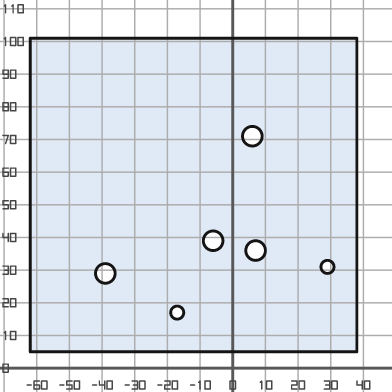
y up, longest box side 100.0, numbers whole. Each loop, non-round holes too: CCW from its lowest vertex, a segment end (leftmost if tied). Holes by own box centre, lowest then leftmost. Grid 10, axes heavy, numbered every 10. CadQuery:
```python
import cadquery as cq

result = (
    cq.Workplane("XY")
    .moveTo(-62.0, 5.0)
    .lineTo(38.0, 5.0)
    .lineTo(38.0, 101.0)
    .lineTo(-62.0, 101.0)
    .close()
    .moveTo(-17.0, 17.0)
    .circle(2.0)
    .moveTo(-39.0, 29.0)
    .circle(3.0)
    .moveTo(29.0, 31.0)
    .circle(2.0)
    .moveTo(7.0, 36.0)
    .circle(3.0)
    .moveTo(-6.0, 39.0)
    .circle(3.0)
    .moveTo(6.0, 71.0)
    .circle(3.0)
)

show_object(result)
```